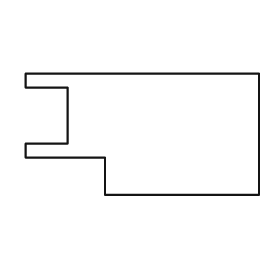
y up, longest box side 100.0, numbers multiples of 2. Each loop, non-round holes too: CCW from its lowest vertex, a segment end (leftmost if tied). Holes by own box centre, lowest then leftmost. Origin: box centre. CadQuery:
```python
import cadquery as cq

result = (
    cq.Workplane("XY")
    .moveTo(-16.0, -26.0)
    .lineTo(50.0, -26.0)
    .lineTo(50.0, 26.0)
    .lineTo(-50.0, 26.0)
    .lineTo(-50.0, 20.0)
    .lineTo(-32.0, 20.0)
    .lineTo(-32.0, -4.0)
    .lineTo(-50.0, -4.0)
    .lineTo(-50.0, -10.0)
    .lineTo(-16.0, -10.0)
    .close()
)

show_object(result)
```